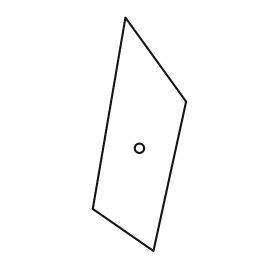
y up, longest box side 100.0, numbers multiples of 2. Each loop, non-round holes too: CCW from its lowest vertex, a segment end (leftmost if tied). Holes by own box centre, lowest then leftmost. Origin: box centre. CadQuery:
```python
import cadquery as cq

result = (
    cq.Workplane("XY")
    .moveTo(6.0, -50.0)
    .lineTo(20.0, 14.0)
    .lineTo(-6.0, 50.0)
    .lineTo(-20.0, -32.0)
    .close()
    .moveTo(0.0, -6.0)
    .circle(2.0)
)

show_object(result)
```